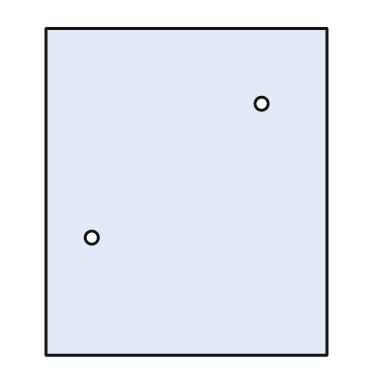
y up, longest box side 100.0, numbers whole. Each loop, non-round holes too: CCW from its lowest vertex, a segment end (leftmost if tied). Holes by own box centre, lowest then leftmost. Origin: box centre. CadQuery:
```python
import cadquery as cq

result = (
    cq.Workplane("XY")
    .moveTo(-43.0, -50.0)
    .lineTo(43.0, -50.0)
    .lineTo(43.0, 50.0)
    .lineTo(-43.0, 50.0)
    .close()
    .moveTo(-29.0, -14.0)
    .circle(2.0)
    .moveTo(23.0, 27.0)
    .circle(2.0)
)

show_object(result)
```